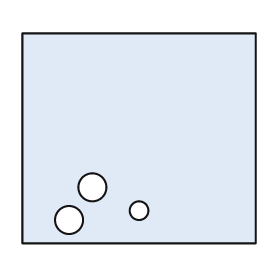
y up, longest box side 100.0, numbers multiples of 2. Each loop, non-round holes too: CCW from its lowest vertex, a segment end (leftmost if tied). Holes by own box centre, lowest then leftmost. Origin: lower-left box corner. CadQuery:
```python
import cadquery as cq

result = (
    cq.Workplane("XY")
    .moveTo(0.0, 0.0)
    .lineTo(100.0, 0.0)
    .lineTo(100.0, 90.0)
    .lineTo(0.0, 90.0)
    .close()
    .moveTo(20.0, 10.0)
    .circle(6.0)
    .moveTo(50.0, 14.0)
    .circle(4.0)
    .moveTo(30.0, 24.0)
    .circle(6.0)
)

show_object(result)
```